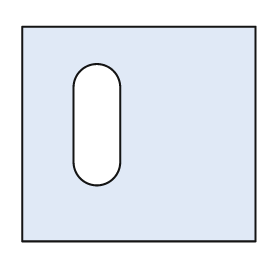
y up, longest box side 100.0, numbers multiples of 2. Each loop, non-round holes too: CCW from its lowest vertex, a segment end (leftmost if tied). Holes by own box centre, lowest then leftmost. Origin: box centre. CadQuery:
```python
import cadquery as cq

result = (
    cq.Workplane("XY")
    .moveTo(-50.0, -46.0)
    .lineTo(50.0, -46.0)
    .lineTo(50.0, 46.0)
    .lineTo(-50.0, 46.0)
    .close()
    .moveTo(-28.0, -12.0)
    .threePointArc((-18.0, -22.0), (-8.0, -12.0))
    .lineTo(-8.0, 20.0)
    .threePointArc((-18.0, 30.0), (-28.0, 20.0))
    .close()
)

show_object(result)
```